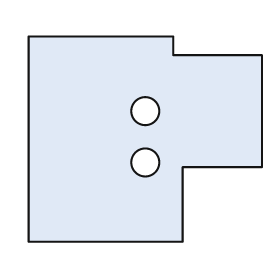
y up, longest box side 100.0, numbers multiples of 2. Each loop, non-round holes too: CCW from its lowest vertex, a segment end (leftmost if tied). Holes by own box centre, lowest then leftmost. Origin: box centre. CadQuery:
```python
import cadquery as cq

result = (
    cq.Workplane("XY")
    .moveTo(-50.0, -44.0)
    .lineTo(16.0, -44.0)
    .lineTo(16.0, -12.0)
    .lineTo(50.0, -12.0)
    .lineTo(50.0, 36.0)
    .lineTo(12.0, 36.0)
    .lineTo(12.0, 44.0)
    .lineTo(-50.0, 44.0)
    .close()
    .moveTo(0.0, -10.0)
    .circle(6.0)
    .moveTo(0.0, 12.0)
    .circle(6.0)
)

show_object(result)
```